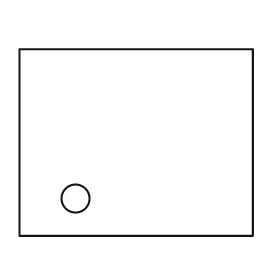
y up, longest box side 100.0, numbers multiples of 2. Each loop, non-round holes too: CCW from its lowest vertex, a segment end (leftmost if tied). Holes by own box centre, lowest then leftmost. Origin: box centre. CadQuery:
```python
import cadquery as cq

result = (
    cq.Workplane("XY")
    .moveTo(-50.0, -40.0)
    .lineTo(50.0, -40.0)
    .lineTo(50.0, 40.0)
    .lineTo(-50.0, 40.0)
    .close()
    .moveTo(-26.0, -24.0)
    .circle(6.0)
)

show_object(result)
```